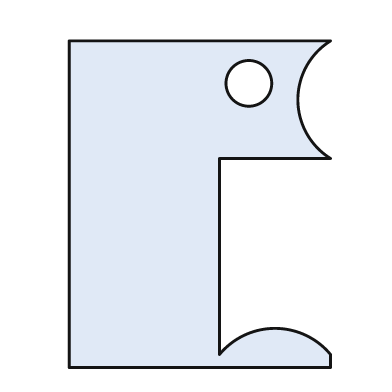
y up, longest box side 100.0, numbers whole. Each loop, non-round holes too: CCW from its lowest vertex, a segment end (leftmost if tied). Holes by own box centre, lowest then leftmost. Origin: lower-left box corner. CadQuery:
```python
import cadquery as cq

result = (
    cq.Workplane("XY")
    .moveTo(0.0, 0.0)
    .lineTo(80.0, 0.0)
    .lineTo(80.0, 4.0)
    .threePointArc((63.0, 12.0), (46.0, 4.0))
    .lineTo(46.0, 64.0)
    .lineTo(80.0, 64.0)
    .threePointArc((70.0, 82.0), (80.0, 100.0))
    .lineTo(0.0, 100.0)
    .close()
    .moveTo(55.0, 87.0)
    .circle(7.0)
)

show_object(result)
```